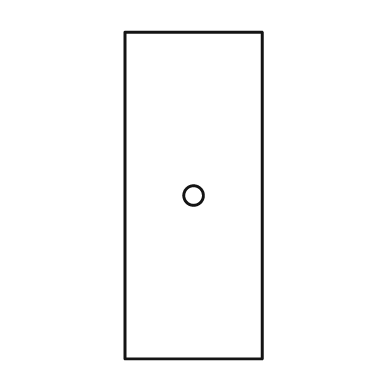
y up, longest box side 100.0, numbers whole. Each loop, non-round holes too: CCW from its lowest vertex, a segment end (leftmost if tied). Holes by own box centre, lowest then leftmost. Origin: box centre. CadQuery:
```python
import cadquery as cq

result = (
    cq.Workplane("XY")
    .moveTo(-21.0, -50.0)
    .lineTo(21.0, -50.0)
    .lineTo(21.0, 50.0)
    .lineTo(-21.0, 50.0)
    .close()
    .moveTo(0.0, 0.0)
    .circle(3.0)
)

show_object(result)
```